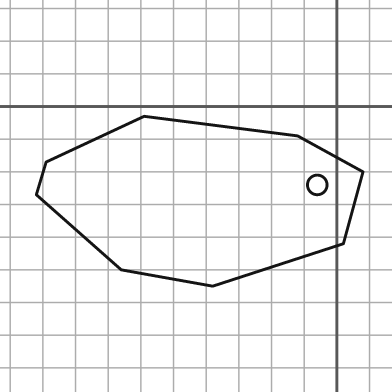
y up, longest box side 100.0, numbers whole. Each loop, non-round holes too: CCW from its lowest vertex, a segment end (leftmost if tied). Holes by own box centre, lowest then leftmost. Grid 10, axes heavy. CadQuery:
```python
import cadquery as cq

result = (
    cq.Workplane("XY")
    .moveTo(-38.0, -55.0)
    .lineTo(2.0, -42.0)
    .lineTo(8.0, -20.0)
    .lineTo(-12.0, -9.0)
    .lineTo(-59.0, -3.0)
    .lineTo(-89.0, -17.0)
    .lineTo(-92.0, -27.0)
    .lineTo(-66.0, -50.0)
    .close()
    .moveTo(-6.0, -24.0)
    .circle(3.0)
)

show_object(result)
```